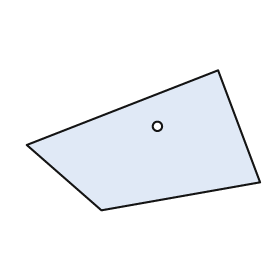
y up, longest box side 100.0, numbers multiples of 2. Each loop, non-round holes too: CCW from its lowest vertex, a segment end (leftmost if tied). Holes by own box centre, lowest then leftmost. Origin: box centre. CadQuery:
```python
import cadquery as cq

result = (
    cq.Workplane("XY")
    .moveTo(-18.0, -30.0)
    .lineTo(50.0, -18.0)
    .lineTo(32.0, 30.0)
    .lineTo(-50.0, -2.0)
    .close()
    .moveTo(6.0, 6.0)
    .circle(2.0)
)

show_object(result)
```